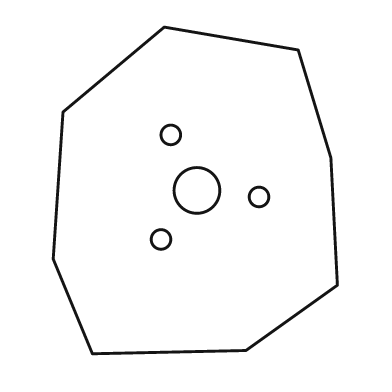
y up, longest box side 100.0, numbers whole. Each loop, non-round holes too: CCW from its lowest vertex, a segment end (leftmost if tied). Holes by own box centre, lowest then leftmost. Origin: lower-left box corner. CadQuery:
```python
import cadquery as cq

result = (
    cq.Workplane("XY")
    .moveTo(12.0, 0.0)
    .lineTo(59.0, 1.0)
    .lineTo(87.0, 21.0)
    .lineTo(85.0, 60.0)
    .lineTo(75.0, 93.0)
    .lineTo(34.0, 100.0)
    .lineTo(3.0, 74.0)
    .lineTo(0.0, 29.0)
    .close()
    .moveTo(33.0, 35.0)
    .circle(3.0)
    .moveTo(63.0, 48.0)
    .circle(3.0)
    .moveTo(44.0, 50.0)
    .circle(7.0)
    .moveTo(36.0, 67.0)
    .circle(3.0)
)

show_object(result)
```